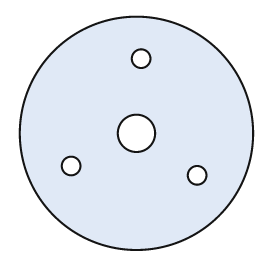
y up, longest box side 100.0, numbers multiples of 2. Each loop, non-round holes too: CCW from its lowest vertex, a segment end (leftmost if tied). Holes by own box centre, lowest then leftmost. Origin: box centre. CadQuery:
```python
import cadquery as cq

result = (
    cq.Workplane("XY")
    .moveTo(0.0, 0.0)
    .circle(50.0)
    .moveTo(26.0, -18.0)
    .circle(4.0)
    .moveTo(-28.0, -14.0)
    .circle(4.0)
    .moveTo(0.0, 0.0)
    .circle(8.0)
    .moveTo(2.0, 32.0)
    .circle(4.0)
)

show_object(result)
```